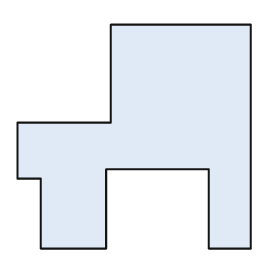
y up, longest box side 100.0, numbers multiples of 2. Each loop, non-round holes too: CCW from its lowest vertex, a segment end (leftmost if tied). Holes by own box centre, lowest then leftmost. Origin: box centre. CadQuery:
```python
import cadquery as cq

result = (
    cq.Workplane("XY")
    .moveTo(-40.0, -48.0)
    .lineTo(-12.0, -48.0)
    .lineTo(-12.0, -14.0)
    .lineTo(32.0, -14.0)
    .lineTo(32.0, -48.0)
    .lineTo(50.0, -48.0)
    .lineTo(50.0, 48.0)
    .lineTo(-10.0, 48.0)
    .lineTo(-10.0, 6.0)
    .lineTo(-50.0, 6.0)
    .lineTo(-50.0, -18.0)
    .lineTo(-40.0, -18.0)
    .close()
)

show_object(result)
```